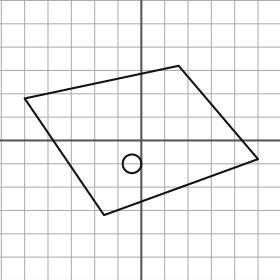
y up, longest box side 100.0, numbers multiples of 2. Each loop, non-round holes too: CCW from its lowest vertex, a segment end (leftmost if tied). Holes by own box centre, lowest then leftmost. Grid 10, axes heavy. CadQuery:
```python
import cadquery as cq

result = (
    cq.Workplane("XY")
    .moveTo(-16.0, -32.0)
    .lineTo(50.0, -8.0)
    .lineTo(16.0, 32.0)
    .lineTo(-50.0, 18.0)
    .close()
    .moveTo(-4.0, -10.0)
    .circle(4.0)
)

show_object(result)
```